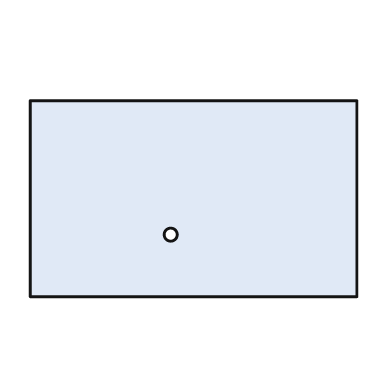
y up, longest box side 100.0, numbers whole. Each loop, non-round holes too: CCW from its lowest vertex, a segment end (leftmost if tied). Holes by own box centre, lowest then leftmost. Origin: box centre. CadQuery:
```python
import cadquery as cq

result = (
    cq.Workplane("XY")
    .moveTo(-50.0, -30.0)
    .lineTo(50.0, -30.0)
    .lineTo(50.0, 30.0)
    .lineTo(-50.0, 30.0)
    .close()
    .moveTo(-7.0, -11.0)
    .circle(2.0)
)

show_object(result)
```